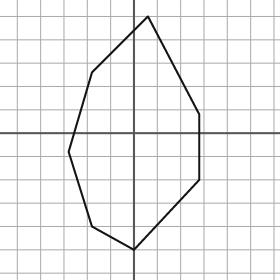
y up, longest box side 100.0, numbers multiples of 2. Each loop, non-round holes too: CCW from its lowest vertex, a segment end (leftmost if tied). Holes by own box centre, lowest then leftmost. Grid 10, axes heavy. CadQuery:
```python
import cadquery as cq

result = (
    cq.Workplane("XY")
    .moveTo(0.0, -50.0)
    .lineTo(28.0, -20.0)
    .lineTo(28.0, 8.0)
    .lineTo(6.0, 50.0)
    .lineTo(-18.0, 26.0)
    .lineTo(-28.0, -8.0)
    .lineTo(-18.0, -40.0)
    .close()
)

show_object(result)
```